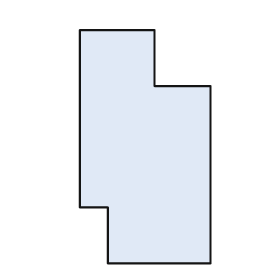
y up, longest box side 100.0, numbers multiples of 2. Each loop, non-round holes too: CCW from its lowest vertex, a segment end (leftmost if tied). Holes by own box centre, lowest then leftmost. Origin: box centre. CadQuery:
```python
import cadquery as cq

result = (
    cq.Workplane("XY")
    .moveTo(-16.0, -50.0)
    .lineTo(28.0, -50.0)
    .lineTo(28.0, 26.0)
    .lineTo(4.0, 26.0)
    .lineTo(4.0, 50.0)
    .lineTo(-28.0, 50.0)
    .lineTo(-28.0, -26.0)
    .lineTo(-16.0, -26.0)
    .close()
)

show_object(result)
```